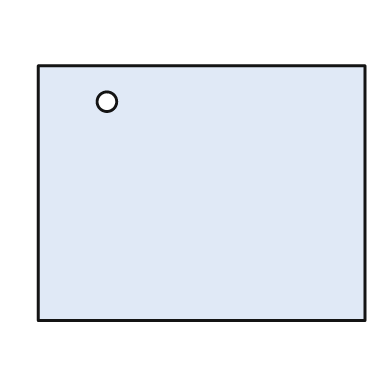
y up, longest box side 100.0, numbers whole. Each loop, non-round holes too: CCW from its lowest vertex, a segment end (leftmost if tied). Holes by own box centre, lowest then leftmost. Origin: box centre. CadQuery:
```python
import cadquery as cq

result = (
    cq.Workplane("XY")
    .moveTo(-50.0, -39.0)
    .lineTo(50.0, -39.0)
    .lineTo(50.0, 39.0)
    .lineTo(-50.0, 39.0)
    .close()
    .moveTo(-29.0, 28.0)
    .circle(3.0)
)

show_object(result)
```